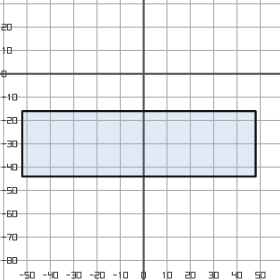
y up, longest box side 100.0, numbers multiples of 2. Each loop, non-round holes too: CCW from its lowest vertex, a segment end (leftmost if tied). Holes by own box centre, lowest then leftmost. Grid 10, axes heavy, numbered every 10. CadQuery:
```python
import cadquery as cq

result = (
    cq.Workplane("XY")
    .moveTo(-52.0, -44.0)
    .lineTo(48.0, -44.0)
    .lineTo(48.0, -16.0)
    .lineTo(-52.0, -16.0)
    .close()
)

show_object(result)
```